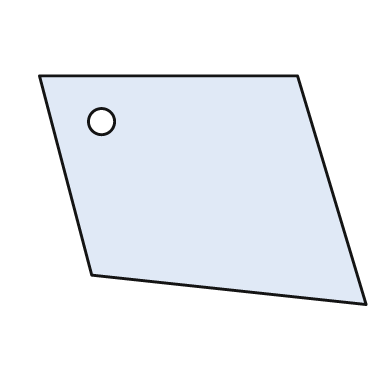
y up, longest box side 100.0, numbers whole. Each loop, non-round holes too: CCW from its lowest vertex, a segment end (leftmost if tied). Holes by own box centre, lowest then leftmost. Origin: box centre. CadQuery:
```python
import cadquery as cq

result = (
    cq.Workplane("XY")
    .moveTo(50.0, -35.0)
    .lineTo(29.0, 35.0)
    .lineTo(-50.0, 35.0)
    .lineTo(-34.0, -26.0)
    .close()
    .moveTo(-31.0, 21.0)
    .circle(4.0)
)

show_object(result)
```